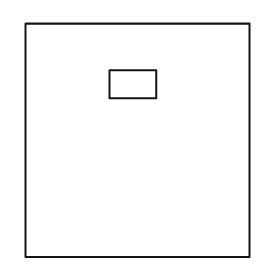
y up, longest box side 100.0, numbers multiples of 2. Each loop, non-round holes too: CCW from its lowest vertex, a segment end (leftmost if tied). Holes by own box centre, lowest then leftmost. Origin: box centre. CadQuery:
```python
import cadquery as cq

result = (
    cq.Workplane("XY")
    .moveTo(-48.0, -50.0)
    .lineTo(48.0, -50.0)
    .lineTo(48.0, 50.0)
    .lineTo(-48.0, 50.0)
    .close()
    .moveTo(-12.0, 18.0)
    .lineTo(8.0, 18.0)
    .lineTo(8.0, 30.0)
    .lineTo(-12.0, 30.0)
    .close()
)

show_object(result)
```